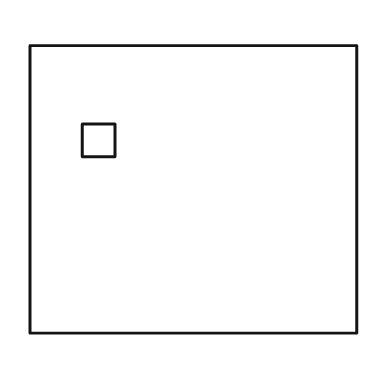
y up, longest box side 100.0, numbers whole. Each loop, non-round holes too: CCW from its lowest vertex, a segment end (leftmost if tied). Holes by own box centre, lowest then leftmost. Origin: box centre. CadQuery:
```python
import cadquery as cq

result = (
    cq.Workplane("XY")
    .moveTo(-50.0, -44.0)
    .lineTo(50.0, -44.0)
    .lineTo(50.0, 44.0)
    .lineTo(-50.0, 44.0)
    .close()
    .moveTo(-34.0, 10.0)
    .lineTo(-24.0, 10.0)
    .lineTo(-24.0, 20.0)
    .lineTo(-34.0, 20.0)
    .close()
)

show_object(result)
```